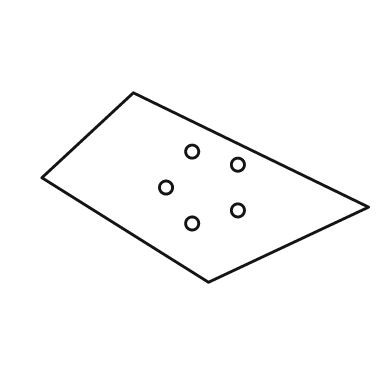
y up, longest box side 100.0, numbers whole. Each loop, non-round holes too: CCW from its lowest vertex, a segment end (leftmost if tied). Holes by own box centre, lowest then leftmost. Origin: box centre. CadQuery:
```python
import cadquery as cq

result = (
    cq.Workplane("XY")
    .moveTo(1.0, -29.0)
    .lineTo(50.0, -6.0)
    .lineTo(-22.0, 29.0)
    .lineTo(-50.0, 3.0)
    .close()
    .moveTo(-4.0, -11.0)
    .circle(2.0)
    .moveTo(10.0, -7.0)
    .circle(2.0)
    .moveTo(-12.0, 0.0)
    .circle(2.0)
    .moveTo(10.0, 7.0)
    .circle(2.0)
    .moveTo(-4.0, 11.0)
    .circle(2.0)
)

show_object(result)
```